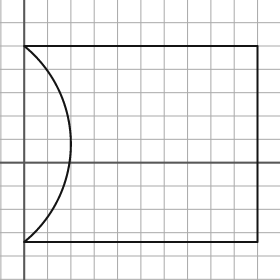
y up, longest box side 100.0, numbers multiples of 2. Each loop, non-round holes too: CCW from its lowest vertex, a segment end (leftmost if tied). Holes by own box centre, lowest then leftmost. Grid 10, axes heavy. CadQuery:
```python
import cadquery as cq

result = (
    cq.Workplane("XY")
    .moveTo(0.0, -34.0)
    .lineTo(100.0, -34.0)
    .lineTo(100.0, 50.0)
    .lineTo(0.0, 50.0)
    .threePointArc((20.0, 8.0), (0.0, -34.0))
    .close()
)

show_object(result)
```